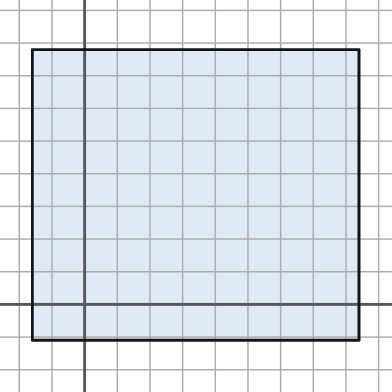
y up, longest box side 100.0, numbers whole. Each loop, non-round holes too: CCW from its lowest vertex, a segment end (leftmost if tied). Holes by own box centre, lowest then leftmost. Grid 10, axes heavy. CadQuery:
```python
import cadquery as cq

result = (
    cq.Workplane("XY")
    .moveTo(-16.0, -11.0)
    .lineTo(84.0, -11.0)
    .lineTo(84.0, 78.0)
    .lineTo(-16.0, 78.0)
    .close()
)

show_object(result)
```